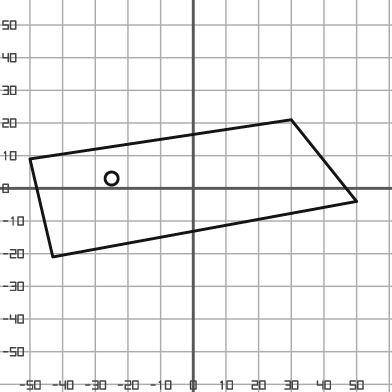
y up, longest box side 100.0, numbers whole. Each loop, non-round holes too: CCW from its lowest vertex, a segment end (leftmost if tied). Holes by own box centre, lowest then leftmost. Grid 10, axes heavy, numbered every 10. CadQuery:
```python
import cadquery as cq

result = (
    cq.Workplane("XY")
    .moveTo(-43.0, -21.0)
    .lineTo(50.0, -4.0)
    .lineTo(30.0, 21.0)
    .lineTo(-50.0, 9.0)
    .close()
    .moveTo(-25.0, 3.0)
    .circle(2.0)
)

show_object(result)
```